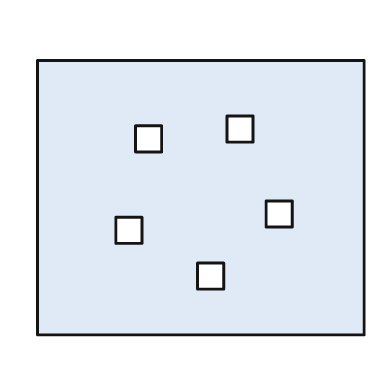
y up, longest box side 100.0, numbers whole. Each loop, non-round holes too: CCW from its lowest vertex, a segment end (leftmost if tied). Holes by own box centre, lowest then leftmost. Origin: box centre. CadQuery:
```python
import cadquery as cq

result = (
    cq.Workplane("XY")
    .moveTo(-50.0, -42.0)
    .lineTo(50.0, -42.0)
    .lineTo(50.0, 42.0)
    .lineTo(-50.0, 42.0)
    .close()
    .moveTo(-1.0, -28.0)
    .lineTo(7.0, -28.0)
    .lineTo(7.0, -20.0)
    .lineTo(-1.0, -20.0)
    .close()
    .moveTo(-26.0, -14.0)
    .lineTo(-18.0, -14.0)
    .lineTo(-18.0, -6.0)
    .lineTo(-26.0, -6.0)
    .close()
    .moveTo(20.0, -9.0)
    .lineTo(28.0, -9.0)
    .lineTo(28.0, -1.0)
    .lineTo(20.0, -1.0)
    .close()
    .moveTo(-20.0, 14.0)
    .lineTo(-12.0, 14.0)
    .lineTo(-12.0, 22.0)
    .lineTo(-20.0, 22.0)
    .close()
    .moveTo(8.0, 17.0)
    .lineTo(16.0, 17.0)
    .lineTo(16.0, 25.0)
    .lineTo(8.0, 25.0)
    .close()
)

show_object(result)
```